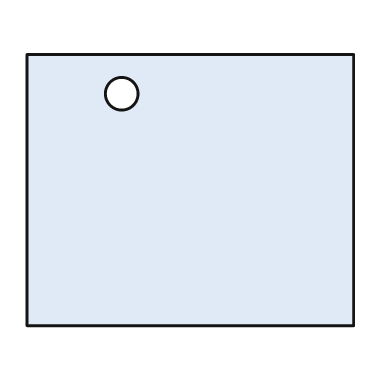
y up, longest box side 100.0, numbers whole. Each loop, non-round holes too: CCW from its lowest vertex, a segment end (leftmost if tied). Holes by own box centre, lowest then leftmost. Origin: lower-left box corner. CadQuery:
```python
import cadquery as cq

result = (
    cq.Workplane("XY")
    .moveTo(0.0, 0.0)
    .lineTo(100.0, 0.0)
    .lineTo(100.0, 83.0)
    .lineTo(0.0, 83.0)
    .close()
    .moveTo(29.0, 71.0)
    .circle(5.0)
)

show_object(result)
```